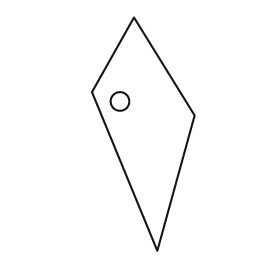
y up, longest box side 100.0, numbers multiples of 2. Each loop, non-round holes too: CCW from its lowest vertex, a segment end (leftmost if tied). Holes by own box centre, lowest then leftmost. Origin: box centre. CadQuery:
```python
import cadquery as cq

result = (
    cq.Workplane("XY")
    .moveTo(6.0, -50.0)
    .lineTo(22.0, 8.0)
    .lineTo(-4.0, 50.0)
    .lineTo(-22.0, 18.0)
    .close()
    .moveTo(-10.0, 14.0)
    .circle(4.0)
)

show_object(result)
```